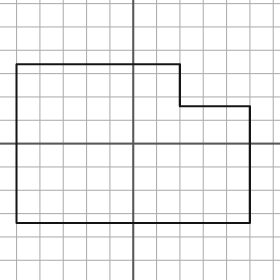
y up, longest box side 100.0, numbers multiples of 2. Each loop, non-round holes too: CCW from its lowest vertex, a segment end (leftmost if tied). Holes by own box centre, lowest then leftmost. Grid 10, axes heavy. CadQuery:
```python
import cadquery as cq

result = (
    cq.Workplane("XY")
    .moveTo(-50.0, -34.0)
    .lineTo(50.0, -34.0)
    .lineTo(50.0, 16.0)
    .lineTo(20.0, 16.0)
    .lineTo(20.0, 34.0)
    .lineTo(-50.0, 34.0)
    .close()
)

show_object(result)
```